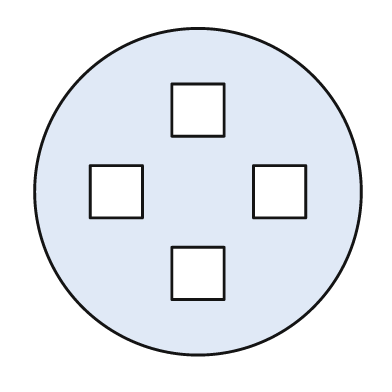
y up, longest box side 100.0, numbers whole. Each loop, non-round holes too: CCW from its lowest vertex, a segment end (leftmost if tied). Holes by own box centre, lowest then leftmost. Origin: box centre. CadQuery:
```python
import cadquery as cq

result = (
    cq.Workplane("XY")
    .moveTo(0.0, 0.0)
    .circle(50.0)
    .moveTo(-8.0, -33.0)
    .lineTo(8.0, -33.0)
    .lineTo(8.0, -17.0)
    .lineTo(-8.0, -17.0)
    .close()
    .moveTo(-33.0, -8.0)
    .lineTo(-17.0, -8.0)
    .lineTo(-17.0, 8.0)
    .lineTo(-33.0, 8.0)
    .close()
    .moveTo(17.0, -8.0)
    .lineTo(33.0, -8.0)
    .lineTo(33.0, 8.0)
    .lineTo(17.0, 8.0)
    .close()
    .moveTo(-8.0, 17.0)
    .lineTo(8.0, 17.0)
    .lineTo(8.0, 33.0)
    .lineTo(-8.0, 33.0)
    .close()
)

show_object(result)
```